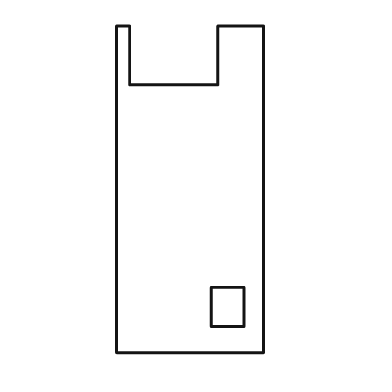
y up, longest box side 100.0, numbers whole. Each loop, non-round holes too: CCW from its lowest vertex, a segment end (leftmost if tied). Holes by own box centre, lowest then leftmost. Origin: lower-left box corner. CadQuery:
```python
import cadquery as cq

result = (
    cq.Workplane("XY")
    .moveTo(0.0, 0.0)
    .lineTo(45.0, 0.0)
    .lineTo(45.0, 100.0)
    .lineTo(31.0, 100.0)
    .lineTo(31.0, 82.0)
    .lineTo(4.0, 82.0)
    .lineTo(4.0, 100.0)
    .lineTo(0.0, 100.0)
    .close()
    .moveTo(29.0, 8.0)
    .lineTo(39.0, 8.0)
    .lineTo(39.0, 20.0)
    .lineTo(29.0, 20.0)
    .close()
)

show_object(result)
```